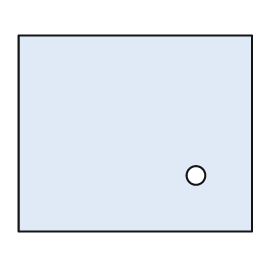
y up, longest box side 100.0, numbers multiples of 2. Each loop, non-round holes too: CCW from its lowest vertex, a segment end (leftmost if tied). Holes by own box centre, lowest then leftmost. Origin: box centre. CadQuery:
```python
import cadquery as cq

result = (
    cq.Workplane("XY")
    .moveTo(-50.0, -42.0)
    .lineTo(50.0, -42.0)
    .lineTo(50.0, 42.0)
    .lineTo(-50.0, 42.0)
    .close()
    .moveTo(26.0, -18.0)
    .circle(4.0)
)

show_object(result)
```